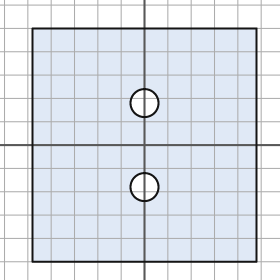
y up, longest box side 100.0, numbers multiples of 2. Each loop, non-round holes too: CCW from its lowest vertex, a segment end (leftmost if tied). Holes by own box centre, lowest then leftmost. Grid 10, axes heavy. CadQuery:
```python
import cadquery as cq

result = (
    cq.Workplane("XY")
    .moveTo(-48.0, -50.0)
    .lineTo(48.0, -50.0)
    .lineTo(48.0, 50.0)
    .lineTo(-48.0, 50.0)
    .close()
    .moveTo(0.0, -18.0)
    .circle(6.0)
    .moveTo(0.0, 18.0)
    .circle(6.0)
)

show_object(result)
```